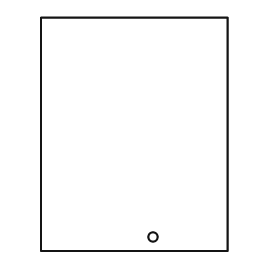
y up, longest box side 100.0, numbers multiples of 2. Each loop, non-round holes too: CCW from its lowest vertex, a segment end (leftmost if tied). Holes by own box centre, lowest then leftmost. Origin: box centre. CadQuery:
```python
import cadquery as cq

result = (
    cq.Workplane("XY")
    .moveTo(-40.0, -50.0)
    .lineTo(40.0, -50.0)
    .lineTo(40.0, 50.0)
    .lineTo(-40.0, 50.0)
    .close()
    .moveTo(8.0, -44.0)
    .circle(2.0)
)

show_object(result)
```